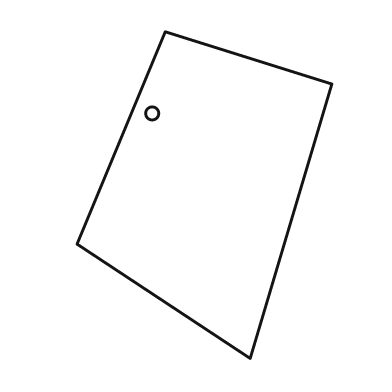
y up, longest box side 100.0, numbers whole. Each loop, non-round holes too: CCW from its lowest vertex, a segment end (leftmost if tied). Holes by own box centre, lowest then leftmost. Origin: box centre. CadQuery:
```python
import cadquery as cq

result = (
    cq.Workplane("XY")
    .moveTo(14.0, -50.0)
    .lineTo(39.0, 34.0)
    .lineTo(-12.0, 50.0)
    .lineTo(-39.0, -15.0)
    .close()
    .moveTo(-16.0, 25.0)
    .circle(2.0)
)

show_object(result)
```